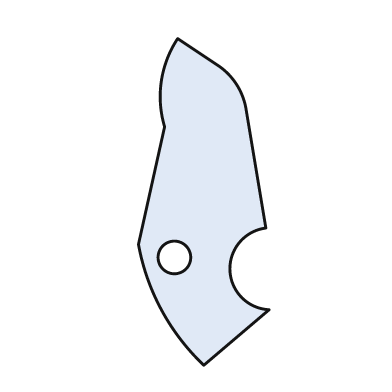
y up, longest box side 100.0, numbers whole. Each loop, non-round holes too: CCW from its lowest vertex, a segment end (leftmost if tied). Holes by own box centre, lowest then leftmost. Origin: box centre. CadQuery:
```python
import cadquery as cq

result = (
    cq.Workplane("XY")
    .moveTo(0.0, -50.0)
    .lineTo(20.0, -33.0)
    .threePointArc((8.0, -21.0), (19.0, -8.0))
    .lineTo(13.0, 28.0)
    .threePointArc((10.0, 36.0), (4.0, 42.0))
    .lineTo(-8.0, 50.0)
    .threePointArc((-13.0, 37.0), (-12.0, 23.0))
    .lineTo(-20.0, -13.0)
    .threePointArc((-13.0, -33.0), (0.0, -50.0))
    .close()
    .moveTo(-9.0, -17.0)
    .circle(5.0)
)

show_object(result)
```